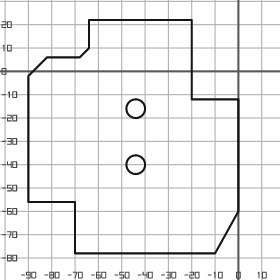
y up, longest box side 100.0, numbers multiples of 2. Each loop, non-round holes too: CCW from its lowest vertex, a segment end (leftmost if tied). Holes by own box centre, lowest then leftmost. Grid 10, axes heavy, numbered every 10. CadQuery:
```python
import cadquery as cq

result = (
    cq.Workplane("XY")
    .moveTo(-70.0, -78.0)
    .lineTo(-10.0, -78.0)
    .lineTo(0.0, -60.0)
    .lineTo(0.0, -12.0)
    .lineTo(-20.0, -12.0)
    .lineTo(-20.0, 22.0)
    .lineTo(-64.0, 22.0)
    .lineTo(-64.0, 10.0)
    .lineTo(-68.0, 6.0)
    .lineTo(-82.0, 6.0)
    .lineTo(-90.0, -2.0)
    .lineTo(-90.0, -56.0)
    .lineTo(-70.0, -56.0)
    .close()
    .moveTo(-44.0, -40.0)
    .circle(4.0)
    .moveTo(-44.0, -16.0)
    .circle(4.0)
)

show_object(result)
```